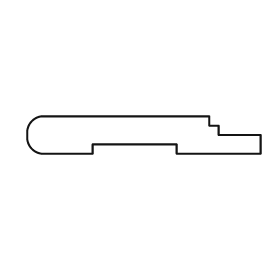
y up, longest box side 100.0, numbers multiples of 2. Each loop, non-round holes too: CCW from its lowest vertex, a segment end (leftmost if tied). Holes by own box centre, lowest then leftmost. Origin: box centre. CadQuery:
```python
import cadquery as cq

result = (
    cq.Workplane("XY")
    .moveTo(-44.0, -8.0)
    .lineTo(-22.0, -8.0)
    .lineTo(-22.0, -4.0)
    .lineTo(14.0, -4.0)
    .lineTo(14.0, -8.0)
    .lineTo(50.0, -8.0)
    .lineTo(50.0, 0.0)
    .lineTo(32.0, 0.0)
    .lineTo(32.0, 4.0)
    .lineTo(28.0, 4.0)
    .lineTo(28.0, 8.0)
    .lineTo(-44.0, 8.0)
    .threePointArc((-48.0, 6.0), (-50.0, 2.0))
    .lineTo(-50.0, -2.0)
    .threePointArc((-48.0, -6.0), (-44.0, -8.0))
    .close()
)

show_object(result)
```